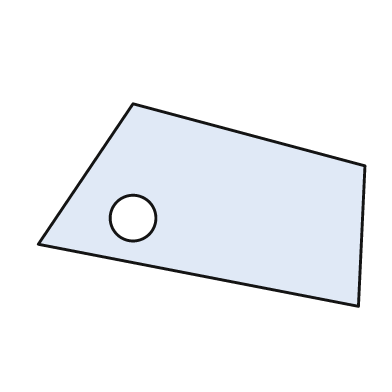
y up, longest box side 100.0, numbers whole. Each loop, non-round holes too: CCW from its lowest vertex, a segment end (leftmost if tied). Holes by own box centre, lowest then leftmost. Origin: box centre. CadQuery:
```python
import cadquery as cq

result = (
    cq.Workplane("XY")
    .moveTo(48.0, -31.0)
    .lineTo(50.0, 12.0)
    .lineTo(-21.0, 31.0)
    .lineTo(-50.0, -12.0)
    .close()
    .moveTo(-21.0, -4.0)
    .circle(7.0)
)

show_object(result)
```